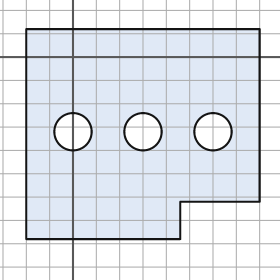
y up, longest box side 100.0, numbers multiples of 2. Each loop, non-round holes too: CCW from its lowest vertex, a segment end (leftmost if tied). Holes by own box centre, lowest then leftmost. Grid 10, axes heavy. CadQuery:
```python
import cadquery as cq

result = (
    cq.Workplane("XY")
    .moveTo(-20.0, -78.0)
    .lineTo(46.0, -78.0)
    .lineTo(46.0, -62.0)
    .lineTo(80.0, -62.0)
    .lineTo(80.0, 12.0)
    .lineTo(-20.0, 12.0)
    .close()
    .moveTo(0.0, -32.0)
    .circle(8.0)
    .moveTo(30.0, -32.0)
    .circle(8.0)
    .moveTo(60.0, -32.0)
    .circle(8.0)
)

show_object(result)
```